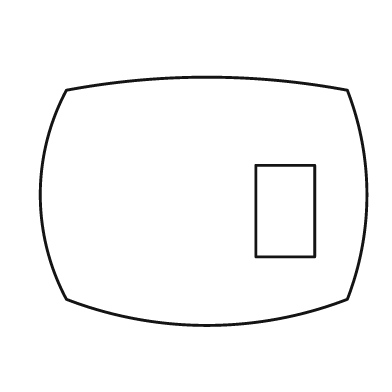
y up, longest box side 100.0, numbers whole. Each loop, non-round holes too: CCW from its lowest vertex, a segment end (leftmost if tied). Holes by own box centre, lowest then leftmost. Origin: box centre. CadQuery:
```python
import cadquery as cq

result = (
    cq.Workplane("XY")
    .moveTo(-42.0, -30.0)
    .threePointArc((1.0, -38.0), (44.0, -30.0))
    .threePointArc((50.0, 2.0), (44.0, 34.0))
    .threePointArc((1.0, 38.0), (-42.0, 34.0))
    .threePointArc((-50.0, 2.0), (-42.0, -30.0))
    .close()
    .moveTo(16.0, -17.0)
    .lineTo(34.0, -17.0)
    .lineTo(34.0, 11.0)
    .lineTo(16.0, 11.0)
    .close()
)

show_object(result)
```